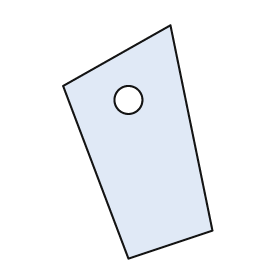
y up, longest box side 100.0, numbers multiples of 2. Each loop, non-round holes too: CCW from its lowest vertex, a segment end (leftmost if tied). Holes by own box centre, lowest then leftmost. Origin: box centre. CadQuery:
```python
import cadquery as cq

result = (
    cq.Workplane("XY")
    .moveTo(-4.0, -50.0)
    .lineTo(32.0, -38.0)
    .lineTo(14.0, 50.0)
    .lineTo(-32.0, 24.0)
    .close()
    .moveTo(-4.0, 18.0)
    .circle(6.0)
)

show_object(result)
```